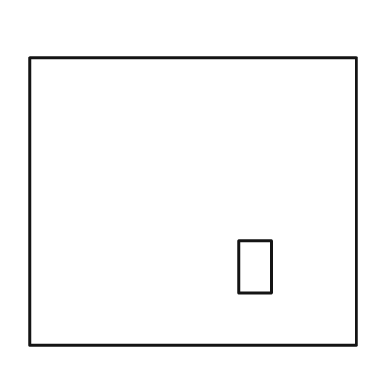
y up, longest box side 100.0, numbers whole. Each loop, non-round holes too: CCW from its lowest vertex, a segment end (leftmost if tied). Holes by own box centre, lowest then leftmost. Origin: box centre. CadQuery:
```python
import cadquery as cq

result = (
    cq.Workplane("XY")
    .moveTo(-50.0, -44.0)
    .lineTo(50.0, -44.0)
    .lineTo(50.0, 44.0)
    .lineTo(-50.0, 44.0)
    .close()
    .moveTo(14.0, -28.0)
    .lineTo(24.0, -28.0)
    .lineTo(24.0, -12.0)
    .lineTo(14.0, -12.0)
    .close()
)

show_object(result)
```